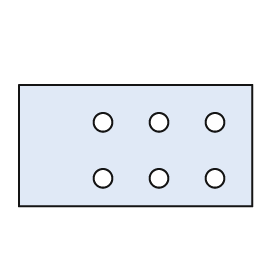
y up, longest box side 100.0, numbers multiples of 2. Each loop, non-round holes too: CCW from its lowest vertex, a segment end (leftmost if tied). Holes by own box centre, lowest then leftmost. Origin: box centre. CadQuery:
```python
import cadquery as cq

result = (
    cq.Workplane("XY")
    .moveTo(-50.0, -26.0)
    .lineTo(50.0, -26.0)
    .lineTo(50.0, 26.0)
    .lineTo(-50.0, 26.0)
    .close()
    .moveTo(-14.0, -14.0)
    .circle(4.0)
    .moveTo(10.0, -14.0)
    .circle(4.0)
    .moveTo(34.0, -14.0)
    .circle(4.0)
    .moveTo(-14.0, 10.0)
    .circle(4.0)
    .moveTo(10.0, 10.0)
    .circle(4.0)
    .moveTo(34.0, 10.0)
    .circle(4.0)
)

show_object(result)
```